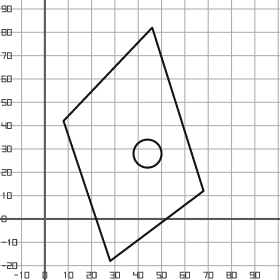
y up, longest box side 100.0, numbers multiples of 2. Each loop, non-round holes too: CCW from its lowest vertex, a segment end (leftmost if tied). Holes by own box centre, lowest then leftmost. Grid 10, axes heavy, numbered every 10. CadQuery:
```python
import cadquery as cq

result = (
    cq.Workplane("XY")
    .moveTo(28.0, -18.0)
    .lineTo(68.0, 12.0)
    .lineTo(46.0, 82.0)
    .lineTo(8.0, 42.0)
    .close()
    .moveTo(44.0, 28.0)
    .circle(6.0)
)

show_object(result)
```